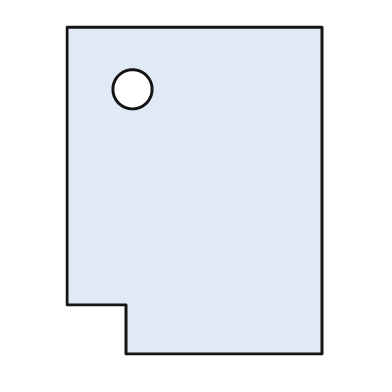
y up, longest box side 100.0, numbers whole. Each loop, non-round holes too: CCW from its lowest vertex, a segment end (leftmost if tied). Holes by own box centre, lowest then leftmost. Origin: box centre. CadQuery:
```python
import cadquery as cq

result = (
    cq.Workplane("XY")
    .moveTo(-21.0, -50.0)
    .lineTo(39.0, -50.0)
    .lineTo(39.0, 50.0)
    .lineTo(-39.0, 50.0)
    .lineTo(-39.0, -35.0)
    .lineTo(-21.0, -35.0)
    .close()
    .moveTo(-19.0, 31.0)
    .circle(6.0)
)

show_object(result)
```